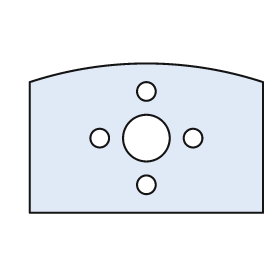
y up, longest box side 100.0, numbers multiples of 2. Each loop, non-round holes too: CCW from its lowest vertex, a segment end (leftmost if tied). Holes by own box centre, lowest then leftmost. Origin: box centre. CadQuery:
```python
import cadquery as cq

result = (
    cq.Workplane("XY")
    .moveTo(-50.0, -32.0)
    .lineTo(50.0, -32.0)
    .lineTo(50.0, 24.0)
    .threePointArc((0.0, 32.0), (-50.0, 24.0))
    .close()
    .moveTo(0.0, -20.0)
    .circle(4.0)
    .moveTo(-20.0, 0.0)
    .circle(4.0)
    .moveTo(0.0, 0.0)
    .circle(10.0)
    .moveTo(20.0, 0.0)
    .circle(4.0)
    .moveTo(0.0, 20.0)
    .circle(4.0)
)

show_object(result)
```